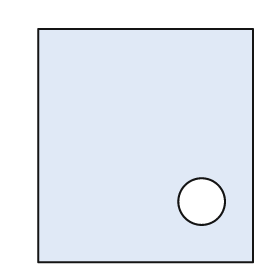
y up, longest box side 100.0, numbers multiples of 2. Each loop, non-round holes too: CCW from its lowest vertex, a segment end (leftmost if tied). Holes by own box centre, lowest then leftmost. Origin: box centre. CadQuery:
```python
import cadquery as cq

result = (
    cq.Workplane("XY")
    .moveTo(-46.0, -50.0)
    .lineTo(46.0, -50.0)
    .lineTo(46.0, 50.0)
    .lineTo(-46.0, 50.0)
    .close()
    .moveTo(24.0, -24.0)
    .circle(10.0)
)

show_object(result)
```